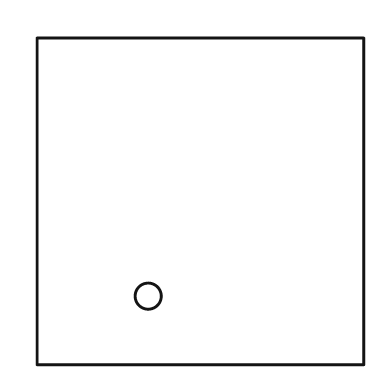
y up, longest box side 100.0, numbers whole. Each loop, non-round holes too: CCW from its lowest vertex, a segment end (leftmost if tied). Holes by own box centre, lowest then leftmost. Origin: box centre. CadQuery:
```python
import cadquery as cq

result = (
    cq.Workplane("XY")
    .moveTo(-50.0, -50.0)
    .lineTo(50.0, -50.0)
    .lineTo(50.0, 50.0)
    .lineTo(-50.0, 50.0)
    .close()
    .moveTo(-16.0, -29.0)
    .circle(4.0)
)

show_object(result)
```